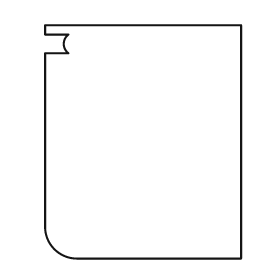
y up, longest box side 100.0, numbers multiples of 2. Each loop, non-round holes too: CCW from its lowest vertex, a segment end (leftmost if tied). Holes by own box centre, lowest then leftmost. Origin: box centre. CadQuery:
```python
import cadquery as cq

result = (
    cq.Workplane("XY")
    .moveTo(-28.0, -50.0)
    .lineTo(42.0, -50.0)
    .lineTo(42.0, 50.0)
    .lineTo(-42.0, 50.0)
    .lineTo(-42.0, 46.0)
    .lineTo(-32.0, 46.0)
    .threePointArc((-34.0, 42.0), (-32.0, 38.0))
    .lineTo(-42.0, 38.0)
    .lineTo(-42.0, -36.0)
    .threePointArc((-38.0, -46.0), (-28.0, -50.0))
    .close()
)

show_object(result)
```